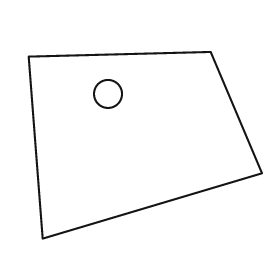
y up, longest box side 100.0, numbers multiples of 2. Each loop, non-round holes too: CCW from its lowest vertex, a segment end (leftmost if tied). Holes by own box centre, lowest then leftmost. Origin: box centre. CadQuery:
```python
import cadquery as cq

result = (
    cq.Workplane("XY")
    .moveTo(-44.0, -40.0)
    .lineTo(50.0, -12.0)
    .lineTo(28.0, 40.0)
    .lineTo(-50.0, 38.0)
    .close()
    .moveTo(-16.0, 22.0)
    .circle(6.0)
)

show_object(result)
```